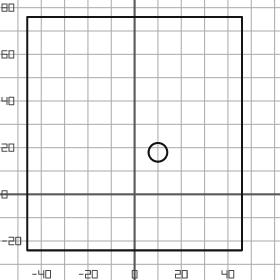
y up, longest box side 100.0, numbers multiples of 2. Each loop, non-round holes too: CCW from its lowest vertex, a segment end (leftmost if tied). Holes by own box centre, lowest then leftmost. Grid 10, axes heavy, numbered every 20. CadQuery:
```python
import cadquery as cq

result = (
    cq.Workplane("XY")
    .moveTo(-46.0, -24.0)
    .lineTo(46.0, -24.0)
    .lineTo(46.0, 76.0)
    .lineTo(-46.0, 76.0)
    .close()
    .moveTo(10.0, 18.0)
    .circle(4.0)
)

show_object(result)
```